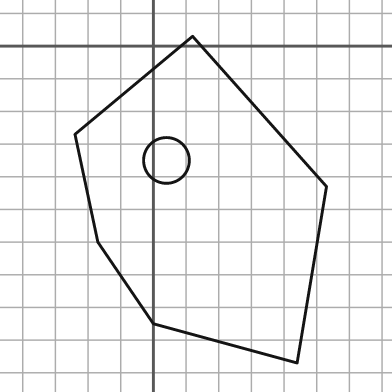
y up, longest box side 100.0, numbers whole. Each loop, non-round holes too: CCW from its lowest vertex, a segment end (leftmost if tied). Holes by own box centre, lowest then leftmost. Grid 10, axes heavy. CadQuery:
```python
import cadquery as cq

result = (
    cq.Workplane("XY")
    .moveTo(44.0, -97.0)
    .lineTo(53.0, -43.0)
    .lineTo(12.0, 3.0)
    .lineTo(-24.0, -27.0)
    .lineTo(-17.0, -60.0)
    .lineTo(0.0, -85.0)
    .close()
    .moveTo(4.0, -35.0)
    .circle(7.0)
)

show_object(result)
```